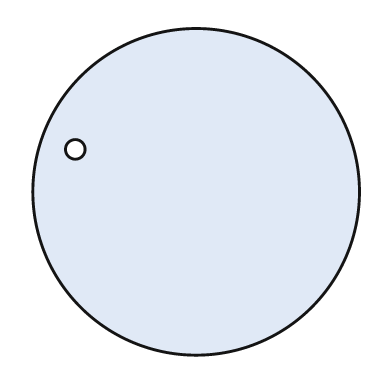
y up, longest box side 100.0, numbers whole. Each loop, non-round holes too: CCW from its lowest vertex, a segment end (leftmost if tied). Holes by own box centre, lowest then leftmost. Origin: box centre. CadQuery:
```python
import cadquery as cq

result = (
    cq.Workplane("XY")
    .moveTo(0.0, 0.0)
    .circle(50.0)
    .moveTo(-37.0, 13.0)
    .circle(3.0)
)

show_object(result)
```